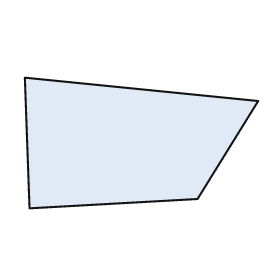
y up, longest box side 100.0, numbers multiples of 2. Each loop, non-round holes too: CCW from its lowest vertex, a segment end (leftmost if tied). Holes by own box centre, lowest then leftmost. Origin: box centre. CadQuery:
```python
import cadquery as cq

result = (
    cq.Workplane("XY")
    .moveTo(-48.0, -28.0)
    .lineTo(24.0, -24.0)
    .lineTo(50.0, 18.0)
    .lineTo(-50.0, 28.0)
    .close()
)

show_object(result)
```